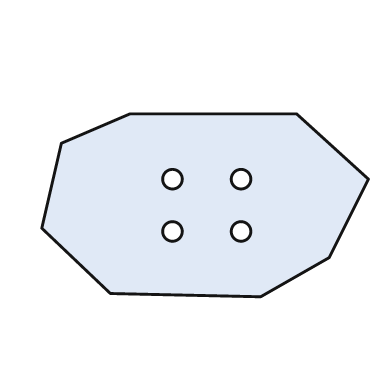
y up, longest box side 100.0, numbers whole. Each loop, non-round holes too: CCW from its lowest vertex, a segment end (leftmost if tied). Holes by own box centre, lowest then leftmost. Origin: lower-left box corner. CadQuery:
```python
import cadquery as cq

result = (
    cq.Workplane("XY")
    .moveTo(67.0, 0.0)
    .lineTo(88.0, 12.0)
    .lineTo(100.0, 36.0)
    .lineTo(78.0, 56.0)
    .lineTo(27.0, 56.0)
    .lineTo(6.0, 47.0)
    .lineTo(0.0, 21.0)
    .lineTo(21.0, 1.0)
    .close()
    .moveTo(40.0, 20.0)
    .circle(3.0)
    .moveTo(61.0, 20.0)
    .circle(3.0)
    .moveTo(40.0, 36.0)
    .circle(3.0)
    .moveTo(61.0, 36.0)
    .circle(3.0)
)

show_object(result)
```